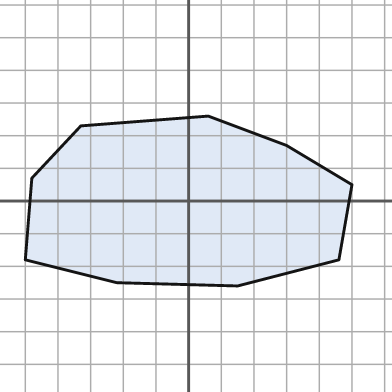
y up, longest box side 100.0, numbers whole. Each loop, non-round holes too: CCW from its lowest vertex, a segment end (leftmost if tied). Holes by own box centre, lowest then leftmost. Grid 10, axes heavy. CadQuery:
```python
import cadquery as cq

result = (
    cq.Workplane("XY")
    .moveTo(15.0, -26.0)
    .lineTo(46.0, -18.0)
    .lineTo(50.0, 5.0)
    .lineTo(30.0, 17.0)
    .lineTo(6.0, 26.0)
    .lineTo(-33.0, 23.0)
    .lineTo(-48.0, 7.0)
    .lineTo(-50.0, -18.0)
    .lineTo(-22.0, -25.0)
    .close()
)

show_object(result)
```